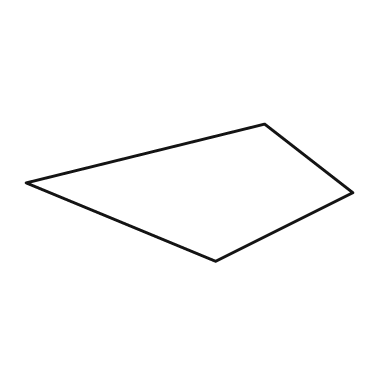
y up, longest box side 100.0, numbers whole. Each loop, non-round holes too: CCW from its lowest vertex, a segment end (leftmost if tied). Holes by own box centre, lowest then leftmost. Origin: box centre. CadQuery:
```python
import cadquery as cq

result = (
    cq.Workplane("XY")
    .moveTo(8.0, -21.0)
    .lineTo(50.0, 0.0)
    .lineTo(23.0, 21.0)
    .lineTo(-50.0, 3.0)
    .close()
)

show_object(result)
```